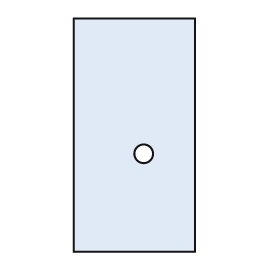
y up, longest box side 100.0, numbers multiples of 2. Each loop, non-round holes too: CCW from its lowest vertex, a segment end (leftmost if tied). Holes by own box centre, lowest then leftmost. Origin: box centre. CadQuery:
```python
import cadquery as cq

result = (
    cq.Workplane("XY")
    .moveTo(-26.0, -50.0)
    .lineTo(26.0, -50.0)
    .lineTo(26.0, 50.0)
    .lineTo(-26.0, 50.0)
    .close()
    .moveTo(4.0, -8.0)
    .circle(4.0)
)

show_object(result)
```